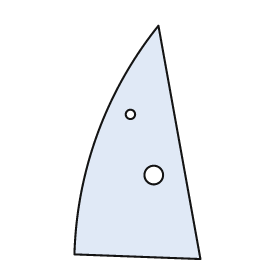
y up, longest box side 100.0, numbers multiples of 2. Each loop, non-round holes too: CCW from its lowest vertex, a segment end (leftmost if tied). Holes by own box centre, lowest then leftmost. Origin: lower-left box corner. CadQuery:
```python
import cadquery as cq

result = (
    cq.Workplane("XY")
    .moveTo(54.0, 0.0)
    .lineTo(36.0, 100.0)
    .threePointArc((10.0, 54.0), (0.0, 2.0))
    .close()
    .moveTo(34.0, 36.0)
    .circle(4.0)
    .moveTo(24.0, 62.0)
    .circle(2.0)
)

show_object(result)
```